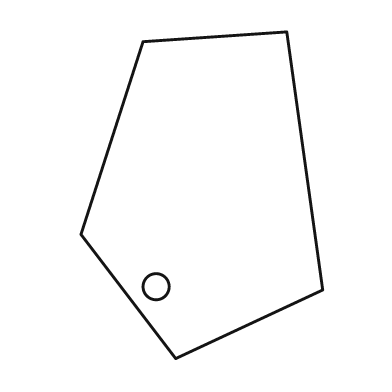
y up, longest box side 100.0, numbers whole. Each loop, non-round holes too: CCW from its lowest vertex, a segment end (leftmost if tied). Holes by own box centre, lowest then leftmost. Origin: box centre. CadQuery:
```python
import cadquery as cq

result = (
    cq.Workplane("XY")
    .moveTo(-8.0, -50.0)
    .lineTo(37.0, -29.0)
    .lineTo(26.0, 50.0)
    .lineTo(-18.0, 47.0)
    .lineTo(-37.0, -12.0)
    .close()
    .moveTo(-14.0, -28.0)
    .circle(4.0)
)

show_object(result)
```